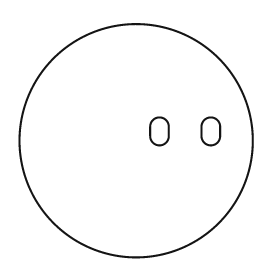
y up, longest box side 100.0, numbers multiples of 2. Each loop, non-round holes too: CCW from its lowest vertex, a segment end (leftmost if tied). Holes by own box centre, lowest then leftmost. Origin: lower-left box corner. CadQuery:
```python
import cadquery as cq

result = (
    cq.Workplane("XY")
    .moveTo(50.0, 50.0)
    .circle(50.0)
    .moveTo(56.0, 52.0)
    .threePointArc((60.0, 48.0), (64.0, 52.0))
    .lineTo(64.0, 56.0)
    .threePointArc((60.0, 60.0), (56.0, 56.0))
    .close()
    .moveTo(78.0, 52.0)
    .threePointArc((82.0, 48.0), (86.0, 52.0))
    .lineTo(86.0, 56.0)
    .threePointArc((82.0, 60.0), (78.0, 56.0))
    .close()
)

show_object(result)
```